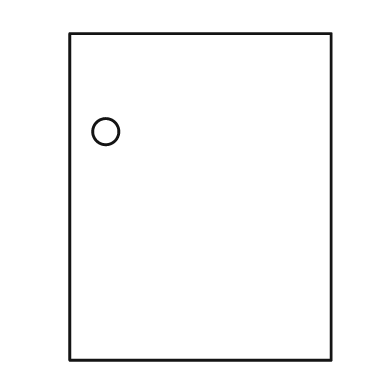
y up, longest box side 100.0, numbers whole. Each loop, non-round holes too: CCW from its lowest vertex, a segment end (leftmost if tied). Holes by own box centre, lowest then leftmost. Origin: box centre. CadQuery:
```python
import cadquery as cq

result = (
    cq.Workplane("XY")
    .moveTo(-40.0, -50.0)
    .lineTo(40.0, -50.0)
    .lineTo(40.0, 50.0)
    .lineTo(-40.0, 50.0)
    .close()
    .moveTo(-29.0, 20.0)
    .circle(4.0)
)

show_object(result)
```